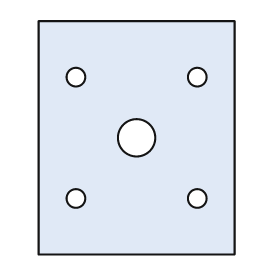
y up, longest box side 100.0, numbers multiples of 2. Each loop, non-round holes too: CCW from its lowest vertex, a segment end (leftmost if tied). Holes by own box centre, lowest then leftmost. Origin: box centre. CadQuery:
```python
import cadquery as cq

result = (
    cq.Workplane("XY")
    .moveTo(-42.0, -50.0)
    .lineTo(42.0, -50.0)
    .lineTo(42.0, 50.0)
    .lineTo(-42.0, 50.0)
    .close()
    .moveTo(-26.0, -26.0)
    .circle(4.0)
    .moveTo(26.0, -26.0)
    .circle(4.0)
    .moveTo(0.0, 0.0)
    .circle(8.0)
    .moveTo(-26.0, 26.0)
    .circle(4.0)
    .moveTo(26.0, 26.0)
    .circle(4.0)
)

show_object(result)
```